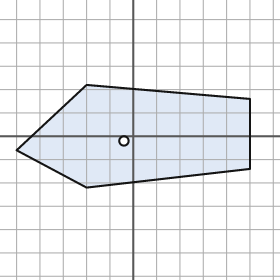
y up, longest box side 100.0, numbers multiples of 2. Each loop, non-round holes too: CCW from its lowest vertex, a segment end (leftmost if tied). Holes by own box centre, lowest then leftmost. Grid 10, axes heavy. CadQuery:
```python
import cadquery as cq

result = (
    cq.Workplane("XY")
    .moveTo(-20.0, -22.0)
    .lineTo(50.0, -14.0)
    .lineTo(50.0, 16.0)
    .lineTo(-20.0, 22.0)
    .lineTo(-50.0, -6.0)
    .close()
    .moveTo(-4.0, -2.0)
    .circle(2.0)
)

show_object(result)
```